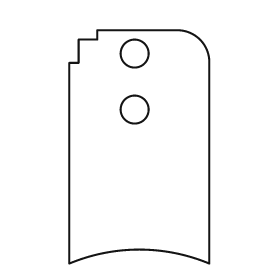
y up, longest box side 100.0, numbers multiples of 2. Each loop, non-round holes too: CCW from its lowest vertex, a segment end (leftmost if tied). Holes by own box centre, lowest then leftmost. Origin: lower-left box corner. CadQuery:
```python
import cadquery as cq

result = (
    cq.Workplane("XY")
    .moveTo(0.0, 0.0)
    .threePointArc((30.0, 6.0), (60.0, 0.0))
    .lineTo(60.0, 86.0)
    .threePointArc((56.0, 96.0), (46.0, 100.0))
    .lineTo(12.0, 100.0)
    .lineTo(12.0, 96.0)
    .lineTo(4.0, 96.0)
    .lineTo(4.0, 86.0)
    .lineTo(0.0, 86.0)
    .close()
    .moveTo(28.0, 66.0)
    .circle(6.0)
    .moveTo(28.0, 90.0)
    .circle(6.0)
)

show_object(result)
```